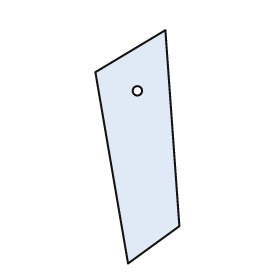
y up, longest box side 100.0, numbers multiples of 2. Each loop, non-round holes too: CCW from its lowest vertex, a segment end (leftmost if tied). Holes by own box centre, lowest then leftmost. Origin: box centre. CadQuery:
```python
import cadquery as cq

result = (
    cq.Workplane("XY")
    .moveTo(-4.0, -50.0)
    .lineTo(18.0, -34.0)
    .lineTo(12.0, 50.0)
    .lineTo(-18.0, 32.0)
    .close()
    .moveTo(0.0, 24.0)
    .circle(2.0)
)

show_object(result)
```